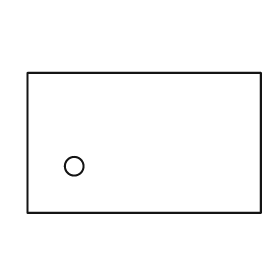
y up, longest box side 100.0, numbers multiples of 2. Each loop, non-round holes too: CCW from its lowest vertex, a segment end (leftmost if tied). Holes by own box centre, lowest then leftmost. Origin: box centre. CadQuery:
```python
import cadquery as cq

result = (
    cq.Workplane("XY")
    .moveTo(-50.0, -30.0)
    .lineTo(50.0, -30.0)
    .lineTo(50.0, 30.0)
    .lineTo(-50.0, 30.0)
    .close()
    .moveTo(-30.0, -10.0)
    .circle(4.0)
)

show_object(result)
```